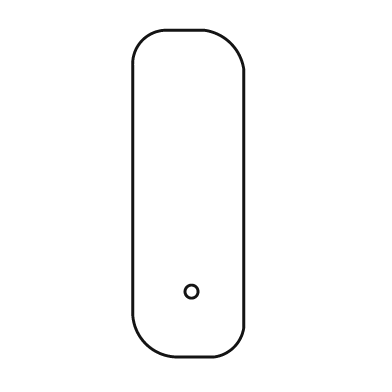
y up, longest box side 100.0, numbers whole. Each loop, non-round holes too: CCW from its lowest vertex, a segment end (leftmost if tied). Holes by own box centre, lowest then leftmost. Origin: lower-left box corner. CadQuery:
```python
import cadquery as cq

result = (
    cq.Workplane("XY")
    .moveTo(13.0, 0.0)
    .lineTo(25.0, 0.0)
    .threePointArc((31.0, 3.0), (34.0, 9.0))
    .lineTo(34.0, 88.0)
    .threePointArc((30.0, 96.0), (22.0, 100.0))
    .lineTo(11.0, 100.0)
    .threePointArc((3.0, 97.0), (0.0, 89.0))
    .lineTo(0.0, 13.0)
    .threePointArc((4.0, 4.0), (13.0, 0.0))
    .close()
    .moveTo(18.0, 20.0)
    .circle(2.0)
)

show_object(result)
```